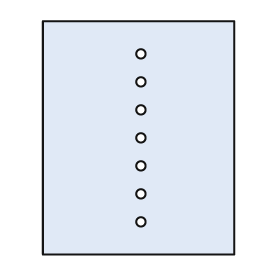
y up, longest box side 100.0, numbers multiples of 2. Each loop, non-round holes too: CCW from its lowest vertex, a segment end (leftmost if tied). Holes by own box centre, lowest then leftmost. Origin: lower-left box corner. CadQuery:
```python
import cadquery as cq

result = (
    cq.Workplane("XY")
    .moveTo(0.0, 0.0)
    .lineTo(82.0, 0.0)
    .lineTo(82.0, 100.0)
    .lineTo(0.0, 100.0)
    .close()
    .moveTo(42.0, 14.0)
    .circle(2.0)
    .moveTo(42.0, 26.0)
    .circle(2.0)
    .moveTo(42.0, 38.0)
    .circle(2.0)
    .moveTo(42.0, 50.0)
    .circle(2.0)
    .moveTo(42.0, 62.0)
    .circle(2.0)
    .moveTo(42.0, 74.0)
    .circle(2.0)
    .moveTo(42.0, 86.0)
    .circle(2.0)
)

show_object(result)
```